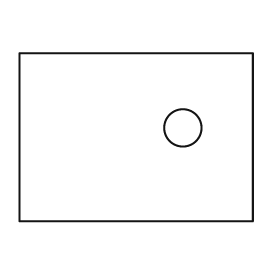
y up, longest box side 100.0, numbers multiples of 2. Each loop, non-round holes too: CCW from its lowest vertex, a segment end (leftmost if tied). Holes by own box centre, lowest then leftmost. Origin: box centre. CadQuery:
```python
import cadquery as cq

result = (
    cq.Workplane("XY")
    .moveTo(-50.0, -36.0)
    .lineTo(50.0, -36.0)
    .lineTo(50.0, 36.0)
    .lineTo(-50.0, 36.0)
    .close()
    .moveTo(20.0, 4.0)
    .circle(8.0)
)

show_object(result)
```